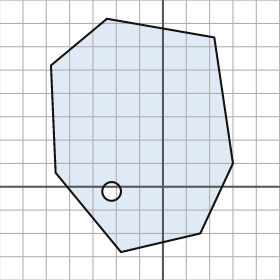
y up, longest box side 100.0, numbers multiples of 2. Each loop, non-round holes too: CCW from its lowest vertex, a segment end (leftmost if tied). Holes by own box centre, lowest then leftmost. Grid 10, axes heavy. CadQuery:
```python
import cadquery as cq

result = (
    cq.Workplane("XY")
    .moveTo(-18.0, -28.0)
    .lineTo(16.0, -20.0)
    .lineTo(30.0, 10.0)
    .lineTo(22.0, 64.0)
    .lineTo(-24.0, 72.0)
    .lineTo(-48.0, 52.0)
    .lineTo(-46.0, 6.0)
    .close()
    .moveTo(-22.0, -2.0)
    .circle(4.0)
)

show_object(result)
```